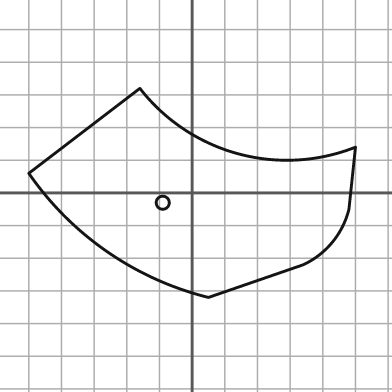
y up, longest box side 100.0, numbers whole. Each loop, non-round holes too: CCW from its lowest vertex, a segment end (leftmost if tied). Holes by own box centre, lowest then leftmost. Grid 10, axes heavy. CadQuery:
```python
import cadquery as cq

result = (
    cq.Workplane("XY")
    .moveTo(5.0, -32.0)
    .lineTo(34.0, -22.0)
    .threePointArc((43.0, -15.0), (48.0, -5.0))
    .lineTo(50.0, 14.0)
    .threePointArc((14.0, 12.0), (-16.0, 32.0))
    .lineTo(-50.0, 6.0)
    .threePointArc((-26.0, -18.0), (5.0, -32.0))
    .close()
    .moveTo(-9.0, -3.0)
    .circle(2.0)
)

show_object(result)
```